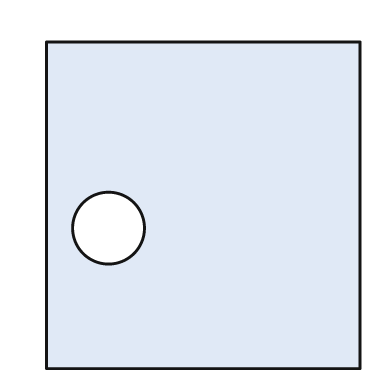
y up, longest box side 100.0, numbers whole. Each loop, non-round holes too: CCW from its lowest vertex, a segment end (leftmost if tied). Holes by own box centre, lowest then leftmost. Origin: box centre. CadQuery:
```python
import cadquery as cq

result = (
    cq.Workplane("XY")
    .moveTo(-48.0, -50.0)
    .lineTo(48.0, -50.0)
    .lineTo(48.0, 50.0)
    .lineTo(-48.0, 50.0)
    .close()
    .moveTo(-29.0, -7.0)
    .circle(11.0)
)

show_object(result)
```